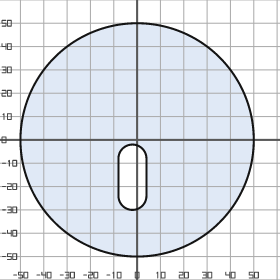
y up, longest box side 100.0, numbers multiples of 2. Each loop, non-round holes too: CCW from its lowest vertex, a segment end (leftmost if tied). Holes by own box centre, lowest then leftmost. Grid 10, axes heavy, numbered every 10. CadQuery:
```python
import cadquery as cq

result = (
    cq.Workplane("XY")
    .moveTo(0.0, 0.0)
    .circle(50.0)
    .moveTo(-8.0, -24.0)
    .threePointArc((-2.0, -30.0), (4.0, -24.0))
    .lineTo(4.0, -8.0)
    .threePointArc((-2.0, -2.0), (-8.0, -8.0))
    .close()
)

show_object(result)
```